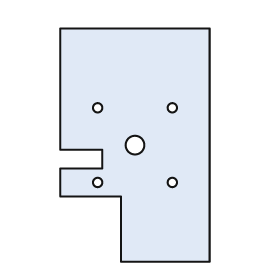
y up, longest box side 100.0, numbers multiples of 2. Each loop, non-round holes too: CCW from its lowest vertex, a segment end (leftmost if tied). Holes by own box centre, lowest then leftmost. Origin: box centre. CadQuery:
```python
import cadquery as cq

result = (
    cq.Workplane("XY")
    .moveTo(-6.0, -50.0)
    .lineTo(32.0, -50.0)
    .lineTo(32.0, 50.0)
    .lineTo(-32.0, 50.0)
    .lineTo(-32.0, -2.0)
    .lineTo(-14.0, -2.0)
    .lineTo(-14.0, -10.0)
    .lineTo(-32.0, -10.0)
    .lineTo(-32.0, -22.0)
    .lineTo(-6.0, -22.0)
    .close()
    .moveTo(-16.0, -16.0)
    .circle(2.0)
    .moveTo(16.0, -16.0)
    .circle(2.0)
    .moveTo(0.0, 0.0)
    .circle(4.0)
    .moveTo(-16.0, 16.0)
    .circle(2.0)
    .moveTo(16.0, 16.0)
    .circle(2.0)
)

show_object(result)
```